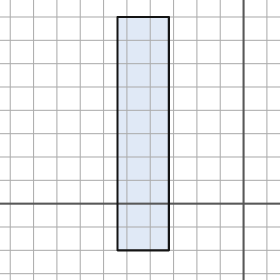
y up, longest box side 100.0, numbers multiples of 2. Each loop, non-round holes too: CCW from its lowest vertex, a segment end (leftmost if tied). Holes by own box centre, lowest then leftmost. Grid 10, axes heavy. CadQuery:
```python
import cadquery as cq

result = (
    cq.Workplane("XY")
    .moveTo(-54.0, -20.0)
    .lineTo(-32.0, -20.0)
    .lineTo(-32.0, 80.0)
    .lineTo(-54.0, 80.0)
    .close()
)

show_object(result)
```